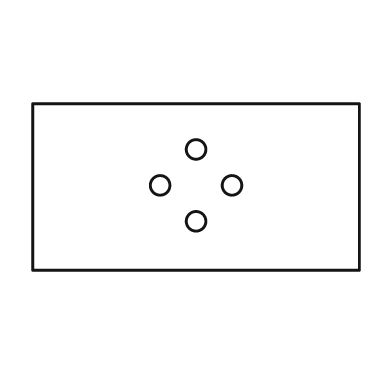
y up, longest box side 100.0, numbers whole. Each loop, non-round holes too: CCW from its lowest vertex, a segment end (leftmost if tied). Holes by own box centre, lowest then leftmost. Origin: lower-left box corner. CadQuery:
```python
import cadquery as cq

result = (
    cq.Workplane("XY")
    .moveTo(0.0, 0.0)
    .lineTo(100.0, 0.0)
    .lineTo(100.0, 51.0)
    .lineTo(0.0, 51.0)
    .close()
    .moveTo(50.0, 15.0)
    .circle(3.0)
    .moveTo(39.0, 26.0)
    .circle(3.0)
    .moveTo(61.0, 26.0)
    .circle(3.0)
    .moveTo(50.0, 37.0)
    .circle(3.0)
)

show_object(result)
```